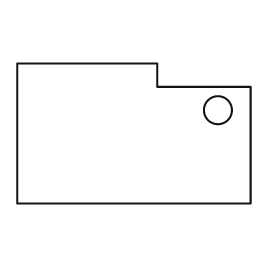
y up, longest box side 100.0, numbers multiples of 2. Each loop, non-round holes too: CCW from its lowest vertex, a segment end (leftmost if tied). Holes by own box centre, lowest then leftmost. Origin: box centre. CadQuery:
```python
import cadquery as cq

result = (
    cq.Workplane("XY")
    .moveTo(-50.0, -30.0)
    .lineTo(50.0, -30.0)
    .lineTo(50.0, 20.0)
    .lineTo(10.0, 20.0)
    .lineTo(10.0, 30.0)
    .lineTo(-50.0, 30.0)
    .close()
    .moveTo(36.0, 10.0)
    .circle(6.0)
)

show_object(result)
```